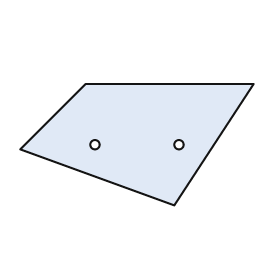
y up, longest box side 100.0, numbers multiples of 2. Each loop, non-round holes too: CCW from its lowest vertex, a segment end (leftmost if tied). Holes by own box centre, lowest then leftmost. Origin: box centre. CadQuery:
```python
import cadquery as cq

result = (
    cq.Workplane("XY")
    .moveTo(16.0, -26.0)
    .lineTo(50.0, 26.0)
    .lineTo(-22.0, 26.0)
    .lineTo(-50.0, -2.0)
    .close()
    .moveTo(-18.0, 0.0)
    .circle(2.0)
    .moveTo(18.0, 0.0)
    .circle(2.0)
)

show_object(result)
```